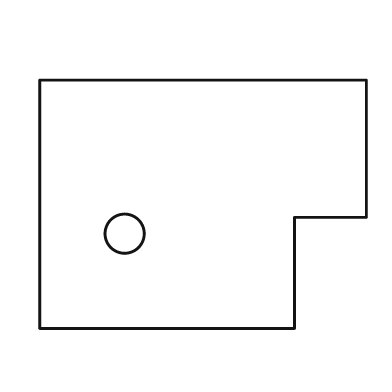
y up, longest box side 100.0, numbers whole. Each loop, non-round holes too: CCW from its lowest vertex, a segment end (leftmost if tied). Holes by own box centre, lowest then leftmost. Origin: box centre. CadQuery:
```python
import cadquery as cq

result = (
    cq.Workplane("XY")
    .moveTo(-50.0, -38.0)
    .lineTo(28.0, -38.0)
    .lineTo(28.0, -4.0)
    .lineTo(50.0, -4.0)
    .lineTo(50.0, 38.0)
    .lineTo(-50.0, 38.0)
    .close()
    .moveTo(-24.0, -9.0)
    .circle(6.0)
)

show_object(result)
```